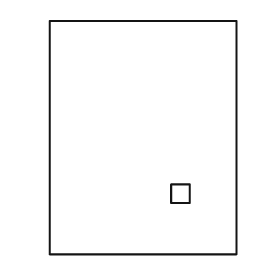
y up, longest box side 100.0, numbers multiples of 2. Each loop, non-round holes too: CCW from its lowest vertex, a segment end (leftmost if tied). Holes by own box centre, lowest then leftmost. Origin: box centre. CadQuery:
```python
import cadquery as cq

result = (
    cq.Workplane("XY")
    .moveTo(-40.0, -50.0)
    .lineTo(40.0, -50.0)
    .lineTo(40.0, 50.0)
    .lineTo(-40.0, 50.0)
    .close()
    .moveTo(12.0, -28.0)
    .lineTo(20.0, -28.0)
    .lineTo(20.0, -20.0)
    .lineTo(12.0, -20.0)
    .close()
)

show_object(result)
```